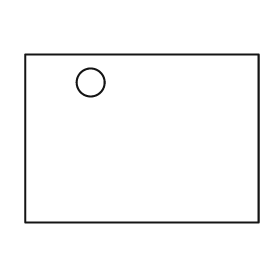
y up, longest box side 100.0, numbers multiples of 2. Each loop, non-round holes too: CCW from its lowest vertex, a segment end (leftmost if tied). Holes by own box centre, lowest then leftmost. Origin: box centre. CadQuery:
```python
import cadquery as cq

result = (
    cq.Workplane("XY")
    .moveTo(-50.0, -36.0)
    .lineTo(50.0, -36.0)
    .lineTo(50.0, 36.0)
    .lineTo(-50.0, 36.0)
    .close()
    .moveTo(-22.0, 24.0)
    .circle(6.0)
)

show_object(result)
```